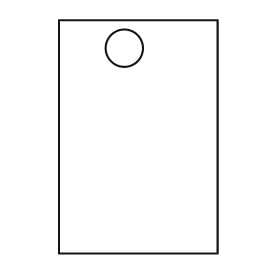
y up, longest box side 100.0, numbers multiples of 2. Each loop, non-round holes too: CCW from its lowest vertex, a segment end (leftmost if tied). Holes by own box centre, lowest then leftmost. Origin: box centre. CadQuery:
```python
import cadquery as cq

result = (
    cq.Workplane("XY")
    .moveTo(-34.0, -50.0)
    .lineTo(34.0, -50.0)
    .lineTo(34.0, 50.0)
    .lineTo(-34.0, 50.0)
    .close()
    .moveTo(-6.0, 38.0)
    .circle(8.0)
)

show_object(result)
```